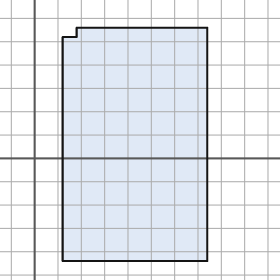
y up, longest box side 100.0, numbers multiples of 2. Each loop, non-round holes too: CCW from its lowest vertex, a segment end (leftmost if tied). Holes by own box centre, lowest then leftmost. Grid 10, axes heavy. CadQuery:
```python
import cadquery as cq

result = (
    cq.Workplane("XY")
    .moveTo(12.0, -44.0)
    .lineTo(74.0, -44.0)
    .lineTo(74.0, 56.0)
    .lineTo(18.0, 56.0)
    .lineTo(18.0, 52.0)
    .lineTo(12.0, 52.0)
    .close()
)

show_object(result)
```